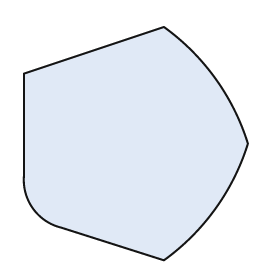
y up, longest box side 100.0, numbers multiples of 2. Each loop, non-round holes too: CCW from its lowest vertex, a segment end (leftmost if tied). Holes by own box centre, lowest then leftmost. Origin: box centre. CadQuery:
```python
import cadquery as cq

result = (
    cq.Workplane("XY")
    .moveTo(12.0, -50.0)
    .threePointArc((34.0, -28.0), (48.0, 0.0))
    .threePointArc((34.0, 28.0), (12.0, 50.0))
    .lineTo(-48.0, 30.0)
    .lineTo(-48.0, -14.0)
    .threePointArc((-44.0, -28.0), (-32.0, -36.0))
    .close()
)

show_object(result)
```